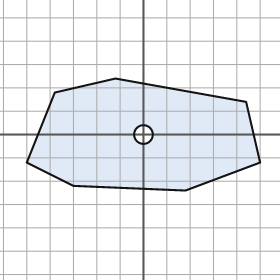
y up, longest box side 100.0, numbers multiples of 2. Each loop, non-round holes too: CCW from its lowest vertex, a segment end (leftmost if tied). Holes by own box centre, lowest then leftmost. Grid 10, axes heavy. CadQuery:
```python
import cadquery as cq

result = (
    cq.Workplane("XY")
    .moveTo(18.0, -24.0)
    .lineTo(50.0, -12.0)
    .lineTo(44.0, 14.0)
    .lineTo(-12.0, 24.0)
    .lineTo(-38.0, 18.0)
    .lineTo(-50.0, -12.0)
    .lineTo(-30.0, -22.0)
    .close()
    .moveTo(0.0, 0.0)
    .circle(4.0)
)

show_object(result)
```